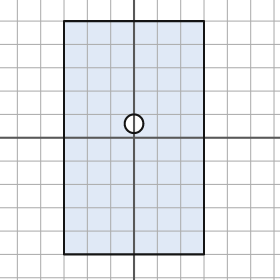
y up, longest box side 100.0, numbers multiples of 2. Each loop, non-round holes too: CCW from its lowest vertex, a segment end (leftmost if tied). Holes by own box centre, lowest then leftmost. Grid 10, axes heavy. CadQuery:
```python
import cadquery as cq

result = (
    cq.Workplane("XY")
    .moveTo(-30.0, -50.0)
    .lineTo(30.0, -50.0)
    .lineTo(30.0, 50.0)
    .lineTo(-30.0, 50.0)
    .close()
    .moveTo(0.0, 6.0)
    .circle(4.0)
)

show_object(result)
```